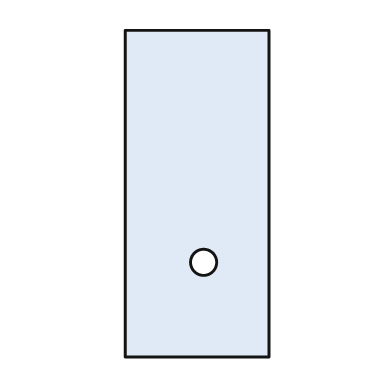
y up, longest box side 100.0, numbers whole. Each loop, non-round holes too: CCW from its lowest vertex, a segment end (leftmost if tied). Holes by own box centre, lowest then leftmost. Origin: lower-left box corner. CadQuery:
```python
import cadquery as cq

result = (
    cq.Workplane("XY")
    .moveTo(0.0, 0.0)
    .lineTo(44.0, 0.0)
    .lineTo(44.0, 100.0)
    .lineTo(0.0, 100.0)
    .close()
    .moveTo(24.0, 29.0)
    .circle(4.0)
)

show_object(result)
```